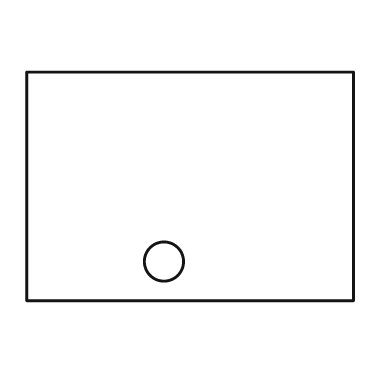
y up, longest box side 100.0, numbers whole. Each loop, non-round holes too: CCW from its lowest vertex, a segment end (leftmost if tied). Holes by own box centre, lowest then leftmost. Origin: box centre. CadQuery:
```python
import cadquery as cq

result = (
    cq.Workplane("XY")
    .moveTo(-50.0, -35.0)
    .lineTo(50.0, -35.0)
    .lineTo(50.0, 35.0)
    .lineTo(-50.0, 35.0)
    .close()
    .moveTo(-8.0, -23.0)
    .circle(6.0)
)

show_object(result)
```